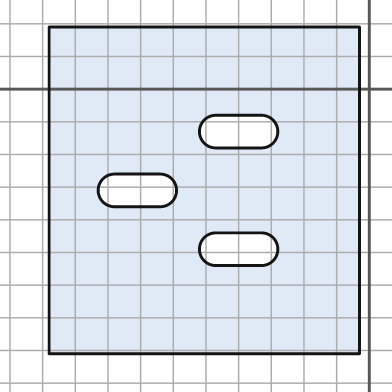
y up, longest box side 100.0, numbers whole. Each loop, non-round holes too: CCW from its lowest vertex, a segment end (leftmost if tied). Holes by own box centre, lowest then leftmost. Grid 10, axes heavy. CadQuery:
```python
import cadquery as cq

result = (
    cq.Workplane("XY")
    .moveTo(-98.0, -81.0)
    .lineTo(-3.0, -81.0)
    .lineTo(-3.0, 19.0)
    .lineTo(-98.0, 19.0)
    .close()
    .moveTo(-47.0, -54.0)
    .lineTo(-33.0, -54.0)
    .threePointArc((-28.0, -49.0), (-33.0, -44.0))
    .lineTo(-47.0, -44.0)
    .threePointArc((-52.0, -49.0), (-47.0, -54.0))
    .close()
    .moveTo(-78.0, -36.0)
    .lineTo(-64.0, -36.0)
    .threePointArc((-59.0, -31.0), (-64.0, -26.0))
    .lineTo(-78.0, -26.0)
    .threePointArc((-83.0, -31.0), (-78.0, -36.0))
    .close()
    .moveTo(-47.0, -18.0)
    .lineTo(-33.0, -18.0)
    .threePointArc((-28.0, -13.0), (-33.0, -8.0))
    .lineTo(-47.0, -8.0)
    .threePointArc((-52.0, -13.0), (-47.0, -18.0))
    .close()
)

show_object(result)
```